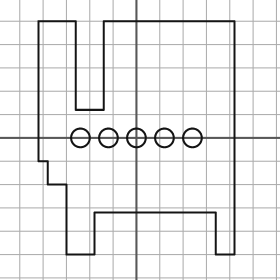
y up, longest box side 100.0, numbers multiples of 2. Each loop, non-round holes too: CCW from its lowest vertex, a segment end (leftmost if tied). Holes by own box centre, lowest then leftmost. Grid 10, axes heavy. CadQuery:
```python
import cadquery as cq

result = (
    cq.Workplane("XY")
    .moveTo(-30.0, -50.0)
    .lineTo(-18.0, -50.0)
    .lineTo(-18.0, -32.0)
    .lineTo(34.0, -32.0)
    .lineTo(34.0, -50.0)
    .lineTo(42.0, -50.0)
    .lineTo(42.0, 50.0)
    .lineTo(-14.0, 50.0)
    .lineTo(-14.0, 12.0)
    .lineTo(-26.0, 12.0)
    .lineTo(-26.0, 50.0)
    .lineTo(-42.0, 50.0)
    .lineTo(-42.0, -10.0)
    .lineTo(-38.0, -10.0)
    .lineTo(-38.0, -20.0)
    .lineTo(-30.0, -20.0)
    .close()
    .moveTo(-24.0, 0.0)
    .circle(4.0)
    .moveTo(-12.0, 0.0)
    .circle(4.0)
    .moveTo(0.0, 0.0)
    .circle(4.0)
    .moveTo(12.0, 0.0)
    .circle(4.0)
    .moveTo(24.0, 0.0)
    .circle(4.0)
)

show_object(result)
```